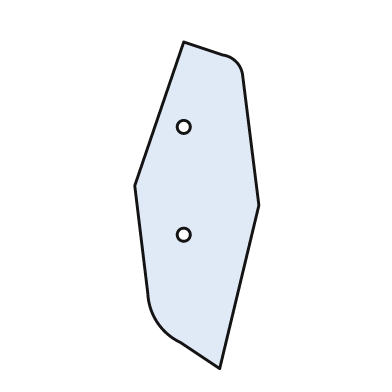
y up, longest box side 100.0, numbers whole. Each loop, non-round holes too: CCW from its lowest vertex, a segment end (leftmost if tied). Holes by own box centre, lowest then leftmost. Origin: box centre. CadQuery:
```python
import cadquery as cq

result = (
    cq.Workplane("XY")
    .moveTo(7.0, -50.0)
    .lineTo(19.0, 0.0)
    .lineTo(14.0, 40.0)
    .threePointArc((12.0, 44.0), (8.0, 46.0))
    .lineTo(-4.0, 50.0)
    .lineTo(-19.0, 6.0)
    .lineTo(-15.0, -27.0)
    .threePointArc((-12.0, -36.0), (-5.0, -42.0))
    .close()
    .moveTo(-4.0, -9.0)
    .circle(2.0)
    .moveTo(-4.0, 24.0)
    .circle(2.0)
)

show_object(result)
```